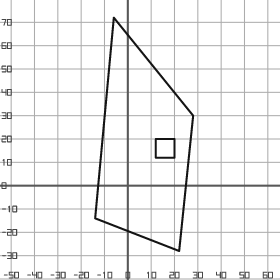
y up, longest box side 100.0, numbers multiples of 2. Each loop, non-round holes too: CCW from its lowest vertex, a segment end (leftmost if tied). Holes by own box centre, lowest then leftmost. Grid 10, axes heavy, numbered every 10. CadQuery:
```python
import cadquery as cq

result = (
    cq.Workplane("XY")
    .moveTo(22.0, -28.0)
    .lineTo(28.0, 30.0)
    .lineTo(-6.0, 72.0)
    .lineTo(-14.0, -14.0)
    .close()
    .moveTo(12.0, 12.0)
    .lineTo(20.0, 12.0)
    .lineTo(20.0, 20.0)
    .lineTo(12.0, 20.0)
    .close()
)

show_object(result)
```